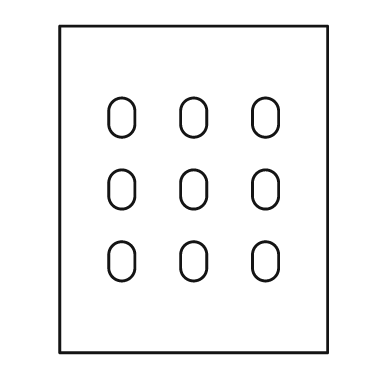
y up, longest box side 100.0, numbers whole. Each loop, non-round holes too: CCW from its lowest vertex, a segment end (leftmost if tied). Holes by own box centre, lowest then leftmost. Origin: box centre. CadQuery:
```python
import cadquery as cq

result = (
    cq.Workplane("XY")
    .moveTo(-41.0, -50.0)
    .lineTo(41.0, -50.0)
    .lineTo(41.0, 50.0)
    .lineTo(-41.0, 50.0)
    .close()
    .moveTo(-26.0, -24.0)
    .threePointArc((-22.0, -28.0), (-18.0, -24.0))
    .lineTo(-18.0, -20.0)
    .threePointArc((-22.0, -16.0), (-26.0, -20.0))
    .close()
    .moveTo(-4.0, -24.0)
    .threePointArc((0.0, -28.0), (4.0, -24.0))
    .lineTo(4.0, -20.0)
    .threePointArc((0.0, -16.0), (-4.0, -20.0))
    .close()
    .moveTo(18.0, -24.0)
    .threePointArc((22.0, -28.0), (26.0, -24.0))
    .lineTo(26.0, -20.0)
    .threePointArc((22.0, -16.0), (18.0, -20.0))
    .close()
    .moveTo(-26.0, -2.0)
    .threePointArc((-22.0, -6.0), (-18.0, -2.0))
    .lineTo(-18.0, 2.0)
    .threePointArc((-22.0, 6.0), (-26.0, 2.0))
    .close()
    .moveTo(-4.0, -2.0)
    .threePointArc((0.0, -6.0), (4.0, -2.0))
    .lineTo(4.0, 2.0)
    .threePointArc((0.0, 6.0), (-4.0, 2.0))
    .close()
    .moveTo(18.0, -2.0)
    .threePointArc((22.0, -6.0), (26.0, -2.0))
    .lineTo(26.0, 2.0)
    .threePointArc((22.0, 6.0), (18.0, 2.0))
    .close()
    .moveTo(-26.0, 20.0)
    .threePointArc((-22.0, 16.0), (-18.0, 20.0))
    .lineTo(-18.0, 24.0)
    .threePointArc((-22.0, 28.0), (-26.0, 24.0))
    .close()
    .moveTo(-4.0, 20.0)
    .threePointArc((0.0, 16.0), (4.0, 20.0))
    .lineTo(4.0, 24.0)
    .threePointArc((0.0, 28.0), (-4.0, 24.0))
    .close()
    .moveTo(18.0, 20.0)
    .threePointArc((22.0, 16.0), (26.0, 20.0))
    .lineTo(26.0, 24.0)
    .threePointArc((22.0, 28.0), (18.0, 24.0))
    .close()
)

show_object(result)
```